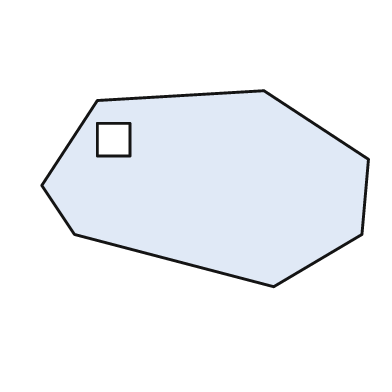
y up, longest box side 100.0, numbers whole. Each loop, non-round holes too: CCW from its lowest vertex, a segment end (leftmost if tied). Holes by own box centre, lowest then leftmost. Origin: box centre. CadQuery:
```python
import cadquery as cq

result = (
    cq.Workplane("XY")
    .moveTo(21.0, -30.0)
    .lineTo(48.0, -14.0)
    .lineTo(50.0, 9.0)
    .lineTo(18.0, 30.0)
    .lineTo(-33.0, 27.0)
    .lineTo(-50.0, 1.0)
    .lineTo(-40.0, -14.0)
    .close()
    .moveTo(-33.0, 10.0)
    .lineTo(-23.0, 10.0)
    .lineTo(-23.0, 20.0)
    .lineTo(-33.0, 20.0)
    .close()
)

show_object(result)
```